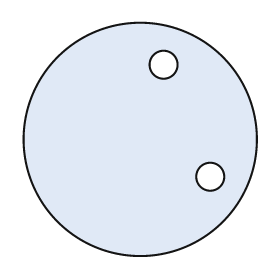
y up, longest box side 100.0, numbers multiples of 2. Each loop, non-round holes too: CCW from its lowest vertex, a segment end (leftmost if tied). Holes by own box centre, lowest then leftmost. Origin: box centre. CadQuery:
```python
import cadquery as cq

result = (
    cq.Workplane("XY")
    .moveTo(0.0, 0.0)
    .circle(50.0)
    .moveTo(30.0, -16.0)
    .circle(6.0)
    .moveTo(10.0, 32.0)
    .circle(6.0)
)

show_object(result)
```